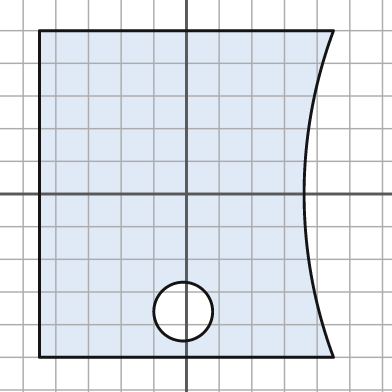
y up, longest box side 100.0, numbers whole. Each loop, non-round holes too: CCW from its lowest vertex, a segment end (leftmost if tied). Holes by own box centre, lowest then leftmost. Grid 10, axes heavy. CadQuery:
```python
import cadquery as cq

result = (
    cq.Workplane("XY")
    .moveTo(-45.0, -50.0)
    .lineTo(45.0, -50.0)
    .threePointArc((36.0, 0.0), (45.0, 50.0))
    .lineTo(-45.0, 50.0)
    .close()
    .moveTo(-1.0, -36.0)
    .circle(9.0)
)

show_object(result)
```